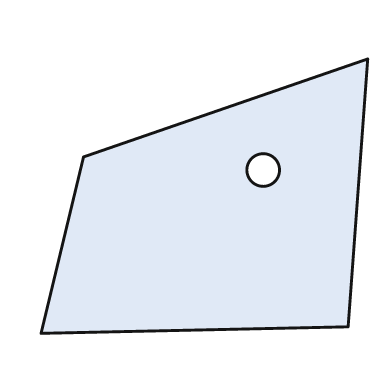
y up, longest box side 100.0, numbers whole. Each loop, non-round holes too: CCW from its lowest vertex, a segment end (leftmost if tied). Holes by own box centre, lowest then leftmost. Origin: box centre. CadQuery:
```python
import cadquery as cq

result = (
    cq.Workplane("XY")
    .moveTo(-50.0, -42.0)
    .lineTo(44.0, -40.0)
    .lineTo(50.0, 42.0)
    .lineTo(-37.0, 12.0)
    .close()
    .moveTo(18.0, 8.0)
    .circle(5.0)
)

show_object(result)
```